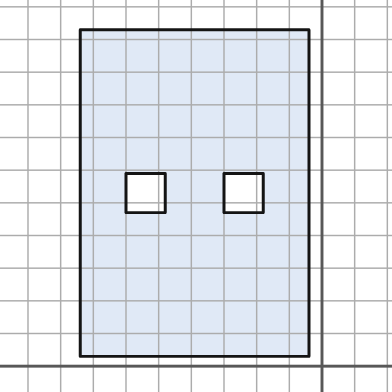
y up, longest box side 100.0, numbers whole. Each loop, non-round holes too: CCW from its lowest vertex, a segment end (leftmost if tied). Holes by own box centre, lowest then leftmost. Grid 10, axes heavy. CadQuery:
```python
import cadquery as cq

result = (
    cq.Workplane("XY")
    .moveTo(-74.0, 3.0)
    .lineTo(-4.0, 3.0)
    .lineTo(-4.0, 103.0)
    .lineTo(-74.0, 103.0)
    .close()
    .moveTo(-60.0, 47.0)
    .lineTo(-48.0, 47.0)
    .lineTo(-48.0, 59.0)
    .lineTo(-60.0, 59.0)
    .close()
    .moveTo(-30.0, 47.0)
    .lineTo(-18.0, 47.0)
    .lineTo(-18.0, 59.0)
    .lineTo(-30.0, 59.0)
    .close()
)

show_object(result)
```